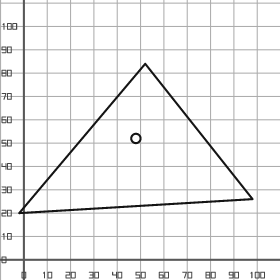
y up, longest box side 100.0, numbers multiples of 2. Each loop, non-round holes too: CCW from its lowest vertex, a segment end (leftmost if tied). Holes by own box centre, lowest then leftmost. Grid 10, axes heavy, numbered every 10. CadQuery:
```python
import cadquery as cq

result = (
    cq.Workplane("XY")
    .moveTo(-2.0, 20.0)
    .lineTo(98.0, 26.0)
    .lineTo(52.0, 84.0)
    .close()
    .moveTo(48.0, 52.0)
    .circle(2.0)
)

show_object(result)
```